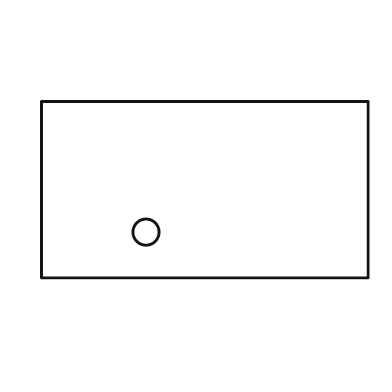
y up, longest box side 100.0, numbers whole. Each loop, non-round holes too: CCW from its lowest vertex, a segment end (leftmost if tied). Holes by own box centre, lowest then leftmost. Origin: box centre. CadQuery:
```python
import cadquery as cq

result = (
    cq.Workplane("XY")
    .moveTo(-50.0, -27.0)
    .lineTo(50.0, -27.0)
    .lineTo(50.0, 27.0)
    .lineTo(-50.0, 27.0)
    .close()
    .moveTo(-18.0, -13.0)
    .circle(4.0)
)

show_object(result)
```